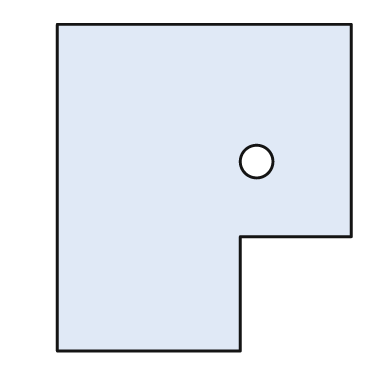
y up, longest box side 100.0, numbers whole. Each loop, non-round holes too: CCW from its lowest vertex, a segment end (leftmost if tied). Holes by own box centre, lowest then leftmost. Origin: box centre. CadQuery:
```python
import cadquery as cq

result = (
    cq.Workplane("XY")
    .moveTo(-45.0, -50.0)
    .lineTo(11.0, -50.0)
    .lineTo(11.0, -15.0)
    .lineTo(45.0, -15.0)
    .lineTo(45.0, 50.0)
    .lineTo(-45.0, 50.0)
    .close()
    .moveTo(16.0, 8.0)
    .circle(5.0)
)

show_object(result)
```